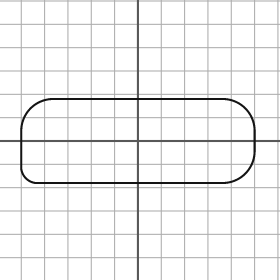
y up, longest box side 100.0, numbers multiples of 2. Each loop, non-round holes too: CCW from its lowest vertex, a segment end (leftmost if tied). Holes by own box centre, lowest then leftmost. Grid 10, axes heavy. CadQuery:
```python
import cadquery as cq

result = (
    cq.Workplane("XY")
    .moveTo(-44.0, -18.0)
    .lineTo(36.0, -18.0)
    .threePointArc((46.0, -14.0), (50.0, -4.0))
    .lineTo(50.0, 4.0)
    .threePointArc((46.0, 14.0), (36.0, 18.0))
    .lineTo(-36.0, 18.0)
    .threePointArc((-46.0, 14.0), (-50.0, 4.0))
    .lineTo(-50.0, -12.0)
    .threePointArc((-48.0, -16.0), (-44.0, -18.0))
    .close()
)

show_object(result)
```